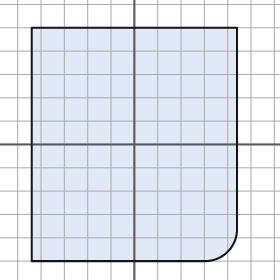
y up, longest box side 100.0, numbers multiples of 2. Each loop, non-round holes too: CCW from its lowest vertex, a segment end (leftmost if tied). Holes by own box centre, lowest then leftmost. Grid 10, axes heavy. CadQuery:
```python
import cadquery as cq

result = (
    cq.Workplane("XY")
    .moveTo(-44.0, -50.0)
    .lineTo(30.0, -50.0)
    .threePointArc((40.0, -46.0), (44.0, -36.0))
    .lineTo(44.0, 50.0)
    .lineTo(-44.0, 50.0)
    .close()
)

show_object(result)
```